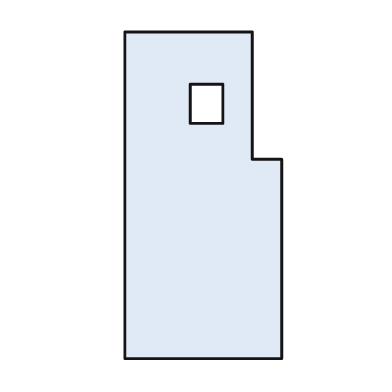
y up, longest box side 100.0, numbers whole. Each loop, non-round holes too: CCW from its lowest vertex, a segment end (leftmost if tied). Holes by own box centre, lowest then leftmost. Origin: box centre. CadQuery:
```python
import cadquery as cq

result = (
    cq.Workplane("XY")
    .moveTo(-24.0, -50.0)
    .lineTo(24.0, -50.0)
    .lineTo(24.0, 11.0)
    .lineTo(15.0, 11.0)
    .lineTo(15.0, 50.0)
    .lineTo(-24.0, 50.0)
    .close()
    .moveTo(-4.0, 22.0)
    .lineTo(6.0, 22.0)
    .lineTo(6.0, 34.0)
    .lineTo(-4.0, 34.0)
    .close()
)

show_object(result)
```